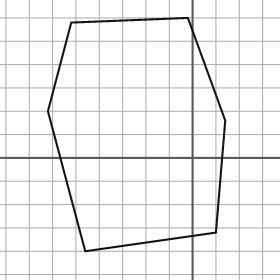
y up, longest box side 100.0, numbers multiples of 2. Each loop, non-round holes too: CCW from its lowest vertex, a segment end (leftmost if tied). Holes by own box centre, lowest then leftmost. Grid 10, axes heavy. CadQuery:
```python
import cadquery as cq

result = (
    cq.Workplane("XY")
    .moveTo(-46.0, -40.0)
    .lineTo(10.0, -32.0)
    .lineTo(14.0, 16.0)
    .lineTo(-2.0, 60.0)
    .lineTo(-52.0, 58.0)
    .lineTo(-62.0, 20.0)
    .close()
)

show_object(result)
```